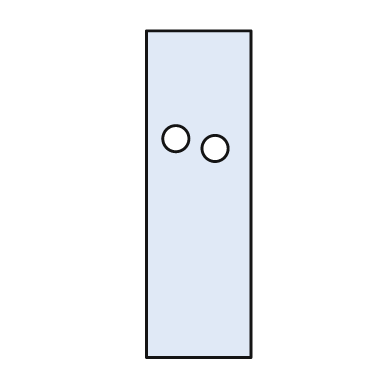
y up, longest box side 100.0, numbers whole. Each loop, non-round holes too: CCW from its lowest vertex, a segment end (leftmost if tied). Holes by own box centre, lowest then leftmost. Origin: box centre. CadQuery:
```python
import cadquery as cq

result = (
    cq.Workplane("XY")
    .moveTo(-16.0, -50.0)
    .lineTo(16.0, -50.0)
    .lineTo(16.0, 50.0)
    .lineTo(-16.0, 50.0)
    .close()
    .moveTo(5.0, 14.0)
    .circle(4.0)
    .moveTo(-7.0, 17.0)
    .circle(4.0)
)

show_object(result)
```